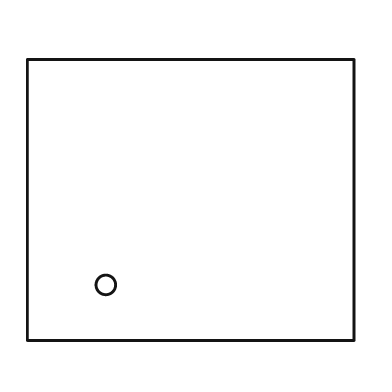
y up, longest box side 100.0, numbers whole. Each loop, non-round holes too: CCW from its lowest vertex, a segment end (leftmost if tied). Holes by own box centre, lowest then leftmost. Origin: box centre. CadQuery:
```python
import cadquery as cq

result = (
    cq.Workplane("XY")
    .moveTo(-50.0, -43.0)
    .lineTo(50.0, -43.0)
    .lineTo(50.0, 43.0)
    .lineTo(-50.0, 43.0)
    .close()
    .moveTo(-26.0, -26.0)
    .circle(3.0)
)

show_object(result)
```